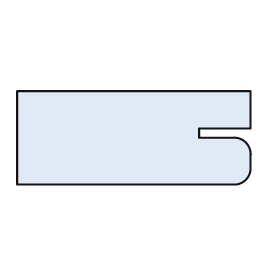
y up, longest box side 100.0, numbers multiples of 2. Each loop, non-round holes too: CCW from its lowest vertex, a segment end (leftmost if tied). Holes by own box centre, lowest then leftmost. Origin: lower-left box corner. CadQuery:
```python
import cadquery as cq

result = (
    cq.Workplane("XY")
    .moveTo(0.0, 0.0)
    .lineTo(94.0, 0.0)
    .threePointArc((98.0, 2.0), (100.0, 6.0))
    .lineTo(100.0, 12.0)
    .threePointArc((98.0, 18.0), (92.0, 20.0))
    .lineTo(78.0, 20.0)
    .lineTo(78.0, 24.0)
    .lineTo(100.0, 24.0)
    .lineTo(100.0, 40.0)
    .lineTo(0.0, 40.0)
    .close()
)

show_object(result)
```